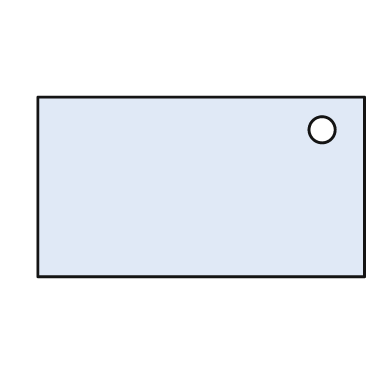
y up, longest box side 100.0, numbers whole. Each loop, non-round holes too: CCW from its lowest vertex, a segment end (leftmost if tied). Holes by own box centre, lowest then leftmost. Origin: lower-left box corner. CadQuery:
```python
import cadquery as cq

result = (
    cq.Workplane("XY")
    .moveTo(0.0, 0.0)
    .lineTo(100.0, 0.0)
    .lineTo(100.0, 55.0)
    .lineTo(0.0, 55.0)
    .close()
    .moveTo(87.0, 45.0)
    .circle(4.0)
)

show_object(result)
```